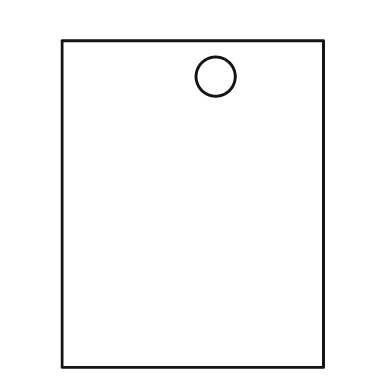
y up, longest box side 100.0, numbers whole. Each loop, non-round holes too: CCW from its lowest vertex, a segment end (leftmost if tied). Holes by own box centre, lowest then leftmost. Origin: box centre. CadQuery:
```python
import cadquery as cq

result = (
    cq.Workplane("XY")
    .moveTo(-40.0, -50.0)
    .lineTo(40.0, -50.0)
    .lineTo(40.0, 50.0)
    .lineTo(-40.0, 50.0)
    .close()
    .moveTo(7.0, 39.0)
    .circle(6.0)
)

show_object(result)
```